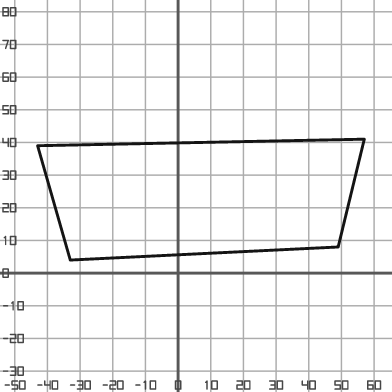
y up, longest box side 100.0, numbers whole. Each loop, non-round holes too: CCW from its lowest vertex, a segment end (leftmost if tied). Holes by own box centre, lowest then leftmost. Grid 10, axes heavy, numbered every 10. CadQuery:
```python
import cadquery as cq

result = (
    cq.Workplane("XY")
    .moveTo(-33.0, 4.0)
    .lineTo(49.0, 8.0)
    .lineTo(57.0, 41.0)
    .lineTo(-43.0, 39.0)
    .close()
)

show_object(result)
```